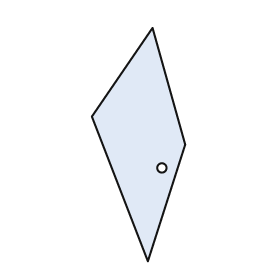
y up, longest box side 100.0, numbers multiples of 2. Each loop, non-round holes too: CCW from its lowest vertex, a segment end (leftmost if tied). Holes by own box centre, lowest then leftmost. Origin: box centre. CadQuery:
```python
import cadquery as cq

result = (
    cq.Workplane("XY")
    .moveTo(4.0, -50.0)
    .lineTo(20.0, 0.0)
    .lineTo(6.0, 50.0)
    .lineTo(-20.0, 12.0)
    .close()
    .moveTo(10.0, -10.0)
    .circle(2.0)
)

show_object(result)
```